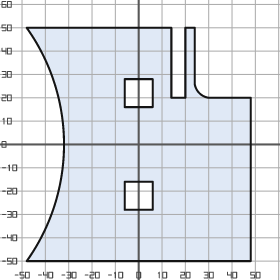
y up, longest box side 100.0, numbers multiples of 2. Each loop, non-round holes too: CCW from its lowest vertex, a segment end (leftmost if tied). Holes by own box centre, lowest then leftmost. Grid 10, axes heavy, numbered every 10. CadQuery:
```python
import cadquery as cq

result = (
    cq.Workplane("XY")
    .moveTo(-48.0, -50.0)
    .lineTo(48.0, -50.0)
    .lineTo(48.0, 20.0)
    .lineTo(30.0, 20.0)
    .threePointArc((26.0, 22.0), (24.0, 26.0))
    .lineTo(24.0, 50.0)
    .lineTo(20.0, 50.0)
    .lineTo(20.0, 20.0)
    .lineTo(14.0, 20.0)
    .lineTo(14.0, 50.0)
    .lineTo(-48.0, 50.0)
    .threePointArc((-32.0, 0.0), (-48.0, -50.0))
    .close()
    .moveTo(-6.0, -28.0)
    .lineTo(6.0, -28.0)
    .lineTo(6.0, -16.0)
    .lineTo(-6.0, -16.0)
    .close()
    .moveTo(-6.0, 16.0)
    .lineTo(6.0, 16.0)
    .lineTo(6.0, 28.0)
    .lineTo(-6.0, 28.0)
    .close()
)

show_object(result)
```